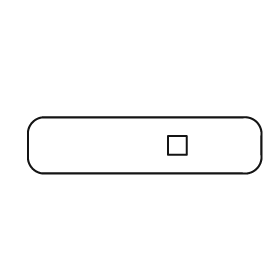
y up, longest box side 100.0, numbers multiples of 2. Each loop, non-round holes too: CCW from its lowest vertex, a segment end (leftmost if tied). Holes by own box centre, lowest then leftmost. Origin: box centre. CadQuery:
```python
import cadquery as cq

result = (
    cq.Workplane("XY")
    .moveTo(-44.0, -12.0)
    .lineTo(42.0, -12.0)
    .threePointArc((48.0, -10.0), (50.0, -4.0))
    .lineTo(50.0, 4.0)
    .threePointArc((48.0, 10.0), (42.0, 12.0))
    .lineTo(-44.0, 12.0)
    .threePointArc((-48.0, 10.0), (-50.0, 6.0))
    .lineTo(-50.0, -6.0)
    .threePointArc((-48.0, -10.0), (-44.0, -12.0))
    .close()
    .moveTo(10.0, -4.0)
    .lineTo(18.0, -4.0)
    .lineTo(18.0, 4.0)
    .lineTo(10.0, 4.0)
    .close()
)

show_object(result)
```